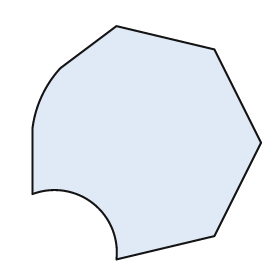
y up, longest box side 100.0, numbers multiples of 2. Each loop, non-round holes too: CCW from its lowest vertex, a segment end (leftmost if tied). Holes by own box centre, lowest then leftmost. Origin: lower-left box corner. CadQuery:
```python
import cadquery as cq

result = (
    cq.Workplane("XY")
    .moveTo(36.0, 0.0)
    .lineTo(78.0, 10.0)
    .lineTo(98.0, 50.0)
    .lineTo(78.0, 90.0)
    .lineTo(36.0, 100.0)
    .lineTo(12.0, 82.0)
    .threePointArc((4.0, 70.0), (0.0, 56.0))
    .lineTo(0.0, 28.0)
    .threePointArc((26.0, 24.0), (36.0, 0.0))
    .close()
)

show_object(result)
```